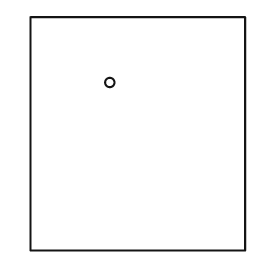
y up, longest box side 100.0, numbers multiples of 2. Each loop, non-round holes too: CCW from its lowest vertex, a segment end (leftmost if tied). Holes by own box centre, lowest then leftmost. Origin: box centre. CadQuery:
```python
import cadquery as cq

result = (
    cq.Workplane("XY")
    .moveTo(-46.0, -50.0)
    .lineTo(46.0, -50.0)
    .lineTo(46.0, 50.0)
    .lineTo(-46.0, 50.0)
    .close()
    .moveTo(-12.0, 22.0)
    .circle(2.0)
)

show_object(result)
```